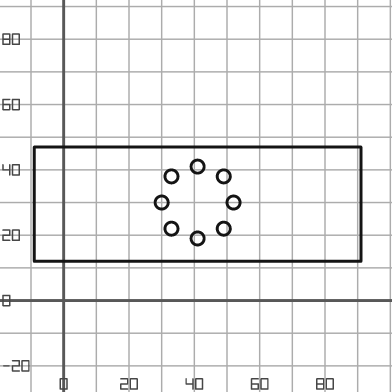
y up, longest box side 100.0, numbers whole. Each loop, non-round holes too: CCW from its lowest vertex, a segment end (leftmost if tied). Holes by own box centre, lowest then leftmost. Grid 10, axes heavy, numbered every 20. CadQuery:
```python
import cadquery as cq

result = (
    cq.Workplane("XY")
    .moveTo(-9.0, 12.0)
    .lineTo(91.0, 12.0)
    .lineTo(91.0, 47.0)
    .lineTo(-9.0, 47.0)
    .close()
    .moveTo(41.0, 19.0)
    .circle(2.0)
    .moveTo(33.0, 22.0)
    .circle(2.0)
    .moveTo(49.0, 22.0)
    .circle(2.0)
    .moveTo(30.0, 30.0)
    .circle(2.0)
    .moveTo(52.0, 30.0)
    .circle(2.0)
    .moveTo(33.0, 38.0)
    .circle(2.0)
    .moveTo(49.0, 38.0)
    .circle(2.0)
    .moveTo(41.0, 41.0)
    .circle(2.0)
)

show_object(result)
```